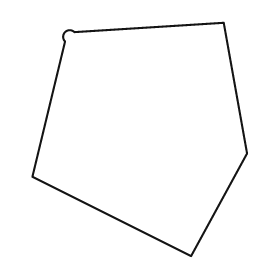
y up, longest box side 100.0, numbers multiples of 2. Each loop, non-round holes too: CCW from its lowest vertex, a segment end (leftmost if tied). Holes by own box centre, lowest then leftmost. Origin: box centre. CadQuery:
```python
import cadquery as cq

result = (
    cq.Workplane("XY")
    .moveTo(22.0, -50.0)
    .lineTo(46.0, -6.0)
    .lineTo(36.0, 50.0)
    .lineTo(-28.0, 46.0)
    .threePointArc((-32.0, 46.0), (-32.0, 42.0))
    .lineTo(-46.0, -16.0)
    .close()
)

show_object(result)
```